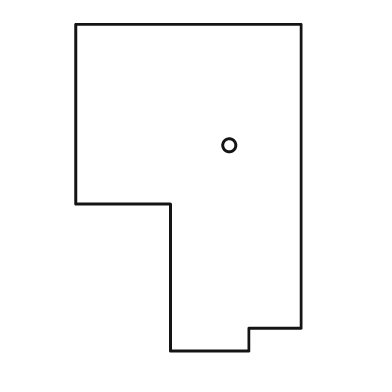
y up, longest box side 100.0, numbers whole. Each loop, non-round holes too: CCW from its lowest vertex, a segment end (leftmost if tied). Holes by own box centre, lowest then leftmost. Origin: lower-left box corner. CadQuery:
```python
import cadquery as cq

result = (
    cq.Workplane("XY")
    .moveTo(29.0, 0.0)
    .lineTo(53.0, 0.0)
    .lineTo(53.0, 7.0)
    .lineTo(69.0, 7.0)
    .lineTo(69.0, 100.0)
    .lineTo(0.0, 100.0)
    .lineTo(0.0, 45.0)
    .lineTo(29.0, 45.0)
    .close()
    .moveTo(47.0, 63.0)
    .circle(2.0)
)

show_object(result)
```